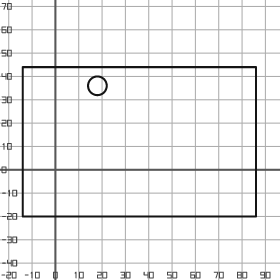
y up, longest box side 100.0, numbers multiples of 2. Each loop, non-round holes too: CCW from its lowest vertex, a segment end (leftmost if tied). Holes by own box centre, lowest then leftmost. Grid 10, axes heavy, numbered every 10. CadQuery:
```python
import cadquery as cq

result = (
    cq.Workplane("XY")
    .moveTo(-14.0, -20.0)
    .lineTo(86.0, -20.0)
    .lineTo(86.0, 44.0)
    .lineTo(-14.0, 44.0)
    .close()
    .moveTo(18.0, 36.0)
    .circle(4.0)
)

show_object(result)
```